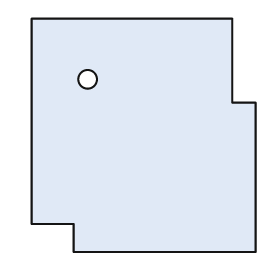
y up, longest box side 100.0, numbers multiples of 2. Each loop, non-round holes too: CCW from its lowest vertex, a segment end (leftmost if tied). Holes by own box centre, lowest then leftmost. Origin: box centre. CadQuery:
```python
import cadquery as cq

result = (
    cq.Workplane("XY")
    .moveTo(-30.0, -50.0)
    .lineTo(48.0, -50.0)
    .lineTo(48.0, 14.0)
    .lineTo(38.0, 14.0)
    .lineTo(38.0, 50.0)
    .lineTo(-48.0, 50.0)
    .lineTo(-48.0, -38.0)
    .lineTo(-30.0, -38.0)
    .close()
    .moveTo(-24.0, 24.0)
    .circle(4.0)
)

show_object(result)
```